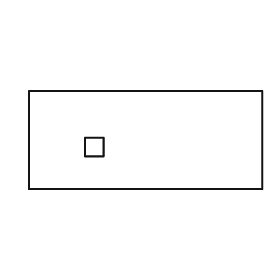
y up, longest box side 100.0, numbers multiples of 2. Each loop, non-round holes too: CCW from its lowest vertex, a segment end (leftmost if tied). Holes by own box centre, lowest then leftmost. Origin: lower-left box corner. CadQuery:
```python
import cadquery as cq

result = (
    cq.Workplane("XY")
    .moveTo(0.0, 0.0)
    .lineTo(100.0, 0.0)
    .lineTo(100.0, 42.0)
    .lineTo(0.0, 42.0)
    .close()
    .moveTo(24.0, 14.0)
    .lineTo(32.0, 14.0)
    .lineTo(32.0, 22.0)
    .lineTo(24.0, 22.0)
    .close()
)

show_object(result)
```